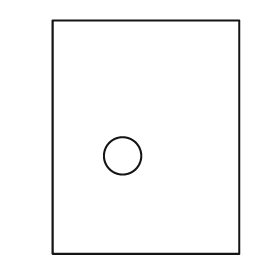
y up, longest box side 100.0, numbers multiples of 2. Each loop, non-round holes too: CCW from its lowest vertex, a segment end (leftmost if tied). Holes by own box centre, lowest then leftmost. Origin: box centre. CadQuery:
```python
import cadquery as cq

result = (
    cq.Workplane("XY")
    .moveTo(-40.0, -50.0)
    .lineTo(40.0, -50.0)
    .lineTo(40.0, 50.0)
    .lineTo(-40.0, 50.0)
    .close()
    .moveTo(-10.0, -8.0)
    .circle(8.0)
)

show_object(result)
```